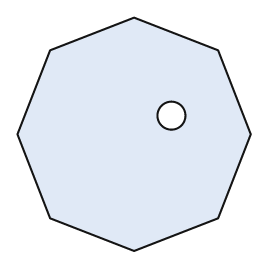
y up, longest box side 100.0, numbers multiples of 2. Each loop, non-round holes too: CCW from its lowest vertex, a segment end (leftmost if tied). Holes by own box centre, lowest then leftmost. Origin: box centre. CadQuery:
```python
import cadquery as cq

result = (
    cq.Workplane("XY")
    .moveTo(0.0, -50.0)
    .lineTo(36.0, -36.0)
    .lineTo(50.0, 0.0)
    .lineTo(36.0, 36.0)
    .lineTo(0.0, 50.0)
    .lineTo(-36.0, 36.0)
    .lineTo(-50.0, 0.0)
    .lineTo(-36.0, -36.0)
    .close()
    .moveTo(16.0, 8.0)
    .circle(6.0)
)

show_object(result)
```